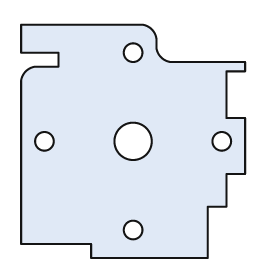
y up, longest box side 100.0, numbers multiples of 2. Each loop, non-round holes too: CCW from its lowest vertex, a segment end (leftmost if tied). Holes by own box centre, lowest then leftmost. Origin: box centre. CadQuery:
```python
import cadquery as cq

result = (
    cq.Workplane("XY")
    .moveTo(-18.0, -50.0)
    .lineTo(32.0, -50.0)
    .lineTo(32.0, -28.0)
    .lineTo(40.0, -28.0)
    .lineTo(40.0, -14.0)
    .lineTo(48.0, -14.0)
    .lineTo(48.0, 10.0)
    .lineTo(40.0, 10.0)
    .lineTo(40.0, 30.0)
    .lineTo(48.0, 30.0)
    .lineTo(48.0, 34.0)
    .lineTo(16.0, 34.0)
    .threePointArc((12.0, 36.0), (10.0, 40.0))
    .lineTo(10.0, 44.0)
    .threePointArc((8.0, 48.0), (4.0, 50.0))
    .lineTo(-48.0, 50.0)
    .lineTo(-48.0, 38.0)
    .lineTo(-32.0, 38.0)
    .lineTo(-32.0, 32.0)
    .lineTo(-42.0, 32.0)
    .threePointArc((-46.0, 30.0), (-48.0, 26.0))
    .lineTo(-48.0, -44.0)
    .lineTo(-18.0, -44.0)
    .close()
    .moveTo(0.0, -38.0)
    .circle(4.0)
    .moveTo(-38.0, 0.0)
    .circle(4.0)
    .moveTo(0.0, 0.0)
    .circle(8.0)
    .moveTo(38.0, 0.0)
    .circle(4.0)
    .moveTo(0.0, 38.0)
    .circle(4.0)
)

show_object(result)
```